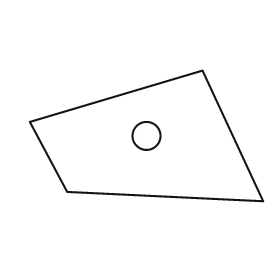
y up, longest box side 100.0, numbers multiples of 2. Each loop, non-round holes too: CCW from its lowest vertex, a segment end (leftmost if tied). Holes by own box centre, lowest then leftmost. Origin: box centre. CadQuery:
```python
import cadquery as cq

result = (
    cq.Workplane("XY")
    .moveTo(50.0, -28.0)
    .lineTo(24.0, 28.0)
    .lineTo(-50.0, 6.0)
    .lineTo(-34.0, -24.0)
    .close()
    .moveTo(0.0, 0.0)
    .circle(6.0)
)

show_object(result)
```